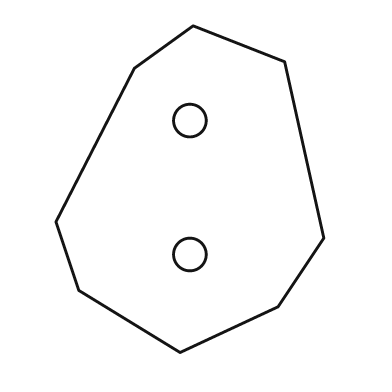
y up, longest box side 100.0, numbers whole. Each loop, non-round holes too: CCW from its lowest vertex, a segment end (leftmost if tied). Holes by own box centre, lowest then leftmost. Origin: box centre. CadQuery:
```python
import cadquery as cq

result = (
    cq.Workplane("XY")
    .moveTo(-3.0, -50.0)
    .lineTo(27.0, -36.0)
    .lineTo(41.0, -15.0)
    .lineTo(29.0, 39.0)
    .lineTo(1.0, 50.0)
    .lineTo(-17.0, 37.0)
    .lineTo(-41.0, -10.0)
    .lineTo(-34.0, -31.0)
    .close()
    .moveTo(0.0, -20.0)
    .circle(5.0)
    .moveTo(0.0, 21.0)
    .circle(5.0)
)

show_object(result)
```